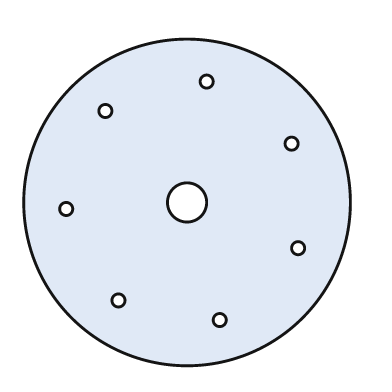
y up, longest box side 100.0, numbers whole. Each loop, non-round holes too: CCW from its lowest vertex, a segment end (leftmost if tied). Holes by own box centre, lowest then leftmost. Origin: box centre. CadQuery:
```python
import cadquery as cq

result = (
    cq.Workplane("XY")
    .moveTo(0.0, 0.0)
    .circle(50.0)
    .moveTo(10.0, -36.0)
    .circle(2.0)
    .moveTo(-21.0, -30.0)
    .circle(2.0)
    .moveTo(34.0, -14.0)
    .circle(2.0)
    .moveTo(-37.0, -2.0)
    .circle(2.0)
    .moveTo(0.0, 0.0)
    .circle(6.0)
    .moveTo(32.0, 18.0)
    .circle(2.0)
    .moveTo(-25.0, 28.0)
    .circle(2.0)
    .moveTo(6.0, 37.0)
    .circle(2.0)
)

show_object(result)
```